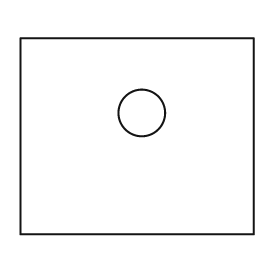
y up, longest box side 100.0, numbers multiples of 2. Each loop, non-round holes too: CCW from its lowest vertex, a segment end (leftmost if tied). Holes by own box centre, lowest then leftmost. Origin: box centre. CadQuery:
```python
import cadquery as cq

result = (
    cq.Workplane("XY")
    .moveTo(-50.0, -42.0)
    .lineTo(50.0, -42.0)
    .lineTo(50.0, 42.0)
    .lineTo(-50.0, 42.0)
    .close()
    .moveTo(2.0, 10.0)
    .circle(10.0)
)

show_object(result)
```